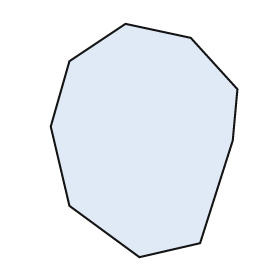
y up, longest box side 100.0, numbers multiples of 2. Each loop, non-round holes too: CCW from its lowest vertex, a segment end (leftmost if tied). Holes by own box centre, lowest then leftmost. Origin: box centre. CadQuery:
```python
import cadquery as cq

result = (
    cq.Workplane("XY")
    .moveTo(-2.0, -50.0)
    .lineTo(24.0, -44.0)
    .lineTo(38.0, 0.0)
    .lineTo(40.0, 22.0)
    .lineTo(20.0, 44.0)
    .lineTo(-8.0, 50.0)
    .lineTo(-32.0, 34.0)
    .lineTo(-40.0, 6.0)
    .lineTo(-32.0, -28.0)
    .close()
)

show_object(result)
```